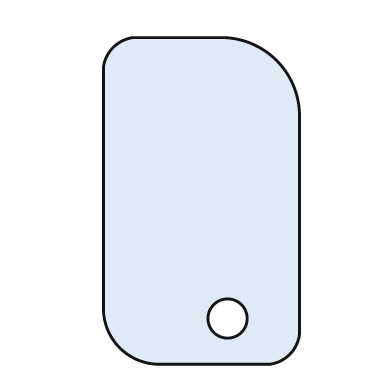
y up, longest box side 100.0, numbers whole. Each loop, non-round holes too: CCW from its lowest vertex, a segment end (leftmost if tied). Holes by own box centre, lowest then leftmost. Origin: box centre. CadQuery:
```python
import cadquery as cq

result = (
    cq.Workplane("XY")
    .moveTo(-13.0, -50.0)
    .lineTo(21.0, -50.0)
    .threePointArc((27.0, -47.0), (30.0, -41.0))
    .lineTo(30.0, 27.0)
    .threePointArc((23.0, 43.0), (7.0, 50.0))
    .lineTo(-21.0, 50.0)
    .threePointArc((-27.0, 47.0), (-30.0, 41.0))
    .lineTo(-30.0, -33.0)
    .threePointArc((-25.0, -45.0), (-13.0, -50.0))
    .close()
    .moveTo(8.0, -36.0)
    .circle(6.0)
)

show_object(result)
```